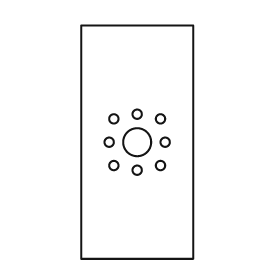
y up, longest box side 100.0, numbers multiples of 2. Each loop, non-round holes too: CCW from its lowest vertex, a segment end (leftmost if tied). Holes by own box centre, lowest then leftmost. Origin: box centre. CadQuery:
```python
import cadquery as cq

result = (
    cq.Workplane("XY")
    .moveTo(-24.0, -50.0)
    .lineTo(24.0, -50.0)
    .lineTo(24.0, 50.0)
    .lineTo(-24.0, 50.0)
    .close()
    .moveTo(0.0, -12.0)
    .circle(2.0)
    .moveTo(-10.0, -10.0)
    .circle(2.0)
    .moveTo(10.0, -10.0)
    .circle(2.0)
    .moveTo(-12.0, 0.0)
    .circle(2.0)
    .moveTo(0.0, 0.0)
    .circle(6.0)
    .moveTo(12.0, 0.0)
    .circle(2.0)
    .moveTo(-10.0, 10.0)
    .circle(2.0)
    .moveTo(10.0, 10.0)
    .circle(2.0)
    .moveTo(0.0, 12.0)
    .circle(2.0)
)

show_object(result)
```